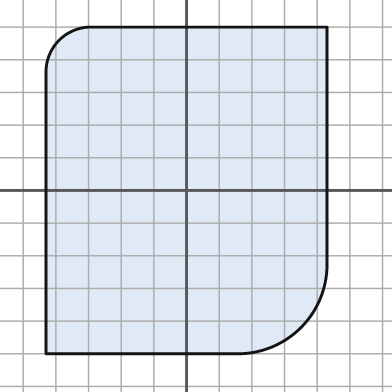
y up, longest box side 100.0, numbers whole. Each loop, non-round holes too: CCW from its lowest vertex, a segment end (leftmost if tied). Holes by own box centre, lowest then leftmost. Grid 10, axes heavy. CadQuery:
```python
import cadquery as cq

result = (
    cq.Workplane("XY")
    .moveTo(-43.0, -50.0)
    .lineTo(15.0, -50.0)
    .threePointArc((35.0, -42.0), (43.0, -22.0))
    .lineTo(43.0, 50.0)
    .lineTo(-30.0, 50.0)
    .threePointArc((-39.0, 46.0), (-43.0, 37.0))
    .close()
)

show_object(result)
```